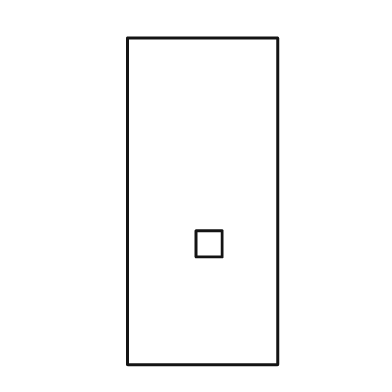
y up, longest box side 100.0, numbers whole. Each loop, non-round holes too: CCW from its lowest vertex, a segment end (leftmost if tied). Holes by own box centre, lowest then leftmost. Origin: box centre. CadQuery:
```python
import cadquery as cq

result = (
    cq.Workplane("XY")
    .moveTo(-23.0, -50.0)
    .lineTo(23.0, -50.0)
    .lineTo(23.0, 50.0)
    .lineTo(-23.0, 50.0)
    .close()
    .moveTo(-2.0, -17.0)
    .lineTo(6.0, -17.0)
    .lineTo(6.0, -9.0)
    .lineTo(-2.0, -9.0)
    .close()
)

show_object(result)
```